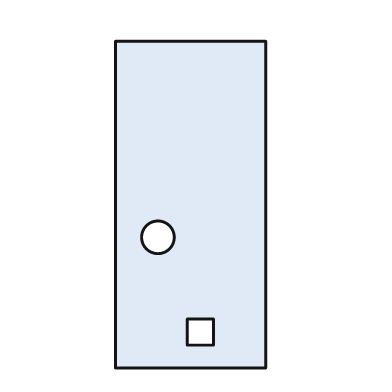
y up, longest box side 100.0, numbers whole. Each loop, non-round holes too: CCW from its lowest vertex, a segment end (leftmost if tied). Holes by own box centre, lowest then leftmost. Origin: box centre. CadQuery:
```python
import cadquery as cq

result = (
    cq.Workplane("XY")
    .moveTo(-23.0, -50.0)
    .lineTo(23.0, -50.0)
    .lineTo(23.0, 50.0)
    .lineTo(-23.0, 50.0)
    .close()
    .moveTo(-1.0, -43.0)
    .lineTo(7.0, -43.0)
    .lineTo(7.0, -35.0)
    .lineTo(-1.0, -35.0)
    .close()
    .moveTo(-10.0, -10.0)
    .circle(5.0)
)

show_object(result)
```